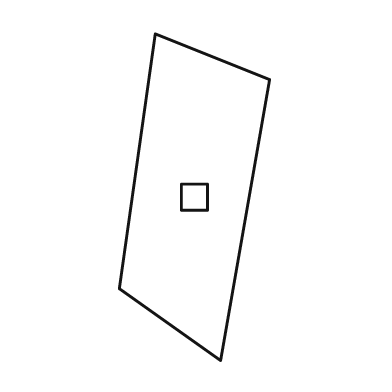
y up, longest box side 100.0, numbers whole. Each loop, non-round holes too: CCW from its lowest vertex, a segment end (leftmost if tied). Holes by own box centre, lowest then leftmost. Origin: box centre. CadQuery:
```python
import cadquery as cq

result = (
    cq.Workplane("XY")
    .moveTo(8.0, -50.0)
    .lineTo(23.0, 36.0)
    .lineTo(-12.0, 50.0)
    .lineTo(-23.0, -28.0)
    .close()
    .moveTo(-4.0, -4.0)
    .lineTo(4.0, -4.0)
    .lineTo(4.0, 4.0)
    .lineTo(-4.0, 4.0)
    .close()
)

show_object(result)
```